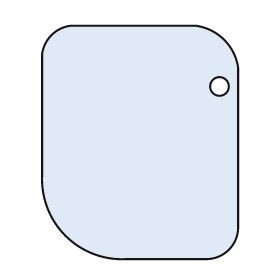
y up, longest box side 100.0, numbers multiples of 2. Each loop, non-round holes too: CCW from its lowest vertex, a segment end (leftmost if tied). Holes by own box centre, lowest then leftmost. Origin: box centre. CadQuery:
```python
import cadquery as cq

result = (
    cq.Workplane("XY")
    .moveTo(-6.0, -50.0)
    .lineTo(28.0, -50.0)
    .threePointArc((38.0, -46.0), (42.0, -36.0))
    .lineTo(42.0, 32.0)
    .threePointArc((36.0, 44.0), (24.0, 50.0))
    .lineTo(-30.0, 50.0)
    .threePointArc((-38.0, 46.0), (-42.0, 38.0))
    .lineTo(-42.0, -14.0)
    .threePointArc((-32.0, -40.0), (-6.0, -50.0))
    .close()
    .moveTo(34.0, 24.0)
    .circle(4.0)
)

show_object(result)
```